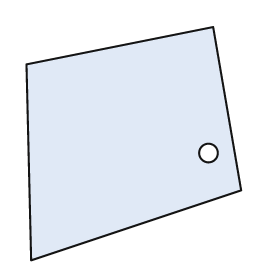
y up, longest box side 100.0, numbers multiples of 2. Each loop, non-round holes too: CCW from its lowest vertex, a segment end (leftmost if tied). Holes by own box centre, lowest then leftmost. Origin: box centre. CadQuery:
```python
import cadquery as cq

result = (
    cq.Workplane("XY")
    .moveTo(-44.0, -50.0)
    .lineTo(46.0, -20.0)
    .lineTo(34.0, 50.0)
    .lineTo(-46.0, 34.0)
    .close()
    .moveTo(32.0, -4.0)
    .circle(4.0)
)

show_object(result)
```